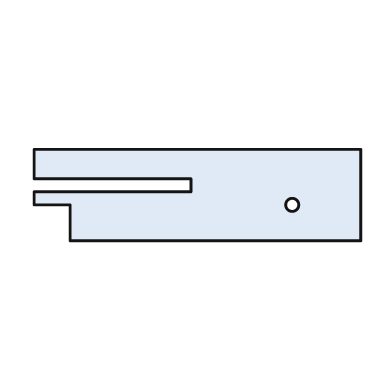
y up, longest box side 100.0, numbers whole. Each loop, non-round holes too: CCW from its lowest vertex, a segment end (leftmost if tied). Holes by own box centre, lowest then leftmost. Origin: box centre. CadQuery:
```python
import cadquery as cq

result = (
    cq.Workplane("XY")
    .moveTo(-39.0, -14.0)
    .lineTo(50.0, -14.0)
    .lineTo(50.0, 14.0)
    .lineTo(-50.0, 14.0)
    .lineTo(-50.0, 5.0)
    .lineTo(-2.0, 5.0)
    .lineTo(-2.0, 1.0)
    .lineTo(-50.0, 1.0)
    .lineTo(-50.0, -3.0)
    .lineTo(-39.0, -3.0)
    .close()
    .moveTo(29.0, -3.0)
    .circle(2.0)
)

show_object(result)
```